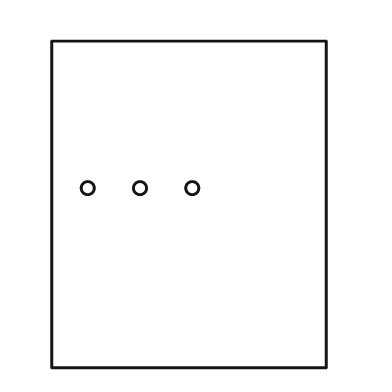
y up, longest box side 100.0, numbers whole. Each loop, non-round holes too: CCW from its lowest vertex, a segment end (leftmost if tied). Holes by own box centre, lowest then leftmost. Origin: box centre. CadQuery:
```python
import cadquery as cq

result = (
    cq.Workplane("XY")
    .moveTo(-42.0, -50.0)
    .lineTo(42.0, -50.0)
    .lineTo(42.0, 50.0)
    .lineTo(-42.0, 50.0)
    .close()
    .moveTo(-31.0, 5.0)
    .circle(2.0)
    .moveTo(-15.0, 5.0)
    .circle(2.0)
    .moveTo(1.0, 5.0)
    .circle(2.0)
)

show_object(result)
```